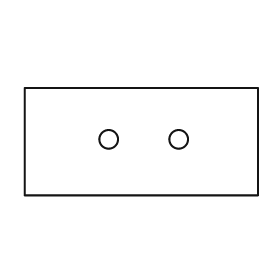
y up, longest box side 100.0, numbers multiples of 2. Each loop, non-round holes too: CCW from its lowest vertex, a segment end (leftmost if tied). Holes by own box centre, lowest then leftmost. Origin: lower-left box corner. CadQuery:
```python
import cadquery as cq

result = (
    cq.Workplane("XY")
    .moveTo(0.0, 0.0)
    .lineTo(100.0, 0.0)
    .lineTo(100.0, 46.0)
    .lineTo(0.0, 46.0)
    .close()
    .moveTo(36.0, 24.0)
    .circle(4.0)
    .moveTo(66.0, 24.0)
    .circle(4.0)
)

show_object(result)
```